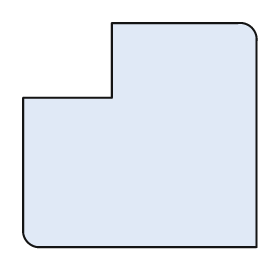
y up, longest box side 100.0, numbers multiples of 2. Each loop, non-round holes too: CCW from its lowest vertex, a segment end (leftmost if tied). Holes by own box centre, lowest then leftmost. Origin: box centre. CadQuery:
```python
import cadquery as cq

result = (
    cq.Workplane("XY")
    .moveTo(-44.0, -48.0)
    .lineTo(50.0, -48.0)
    .lineTo(50.0, 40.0)
    .threePointArc((48.0, 46.0), (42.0, 48.0))
    .lineTo(-12.0, 48.0)
    .lineTo(-12.0, 16.0)
    .lineTo(-50.0, 16.0)
    .lineTo(-50.0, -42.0)
    .threePointArc((-48.0, -46.0), (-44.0, -48.0))
    .close()
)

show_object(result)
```